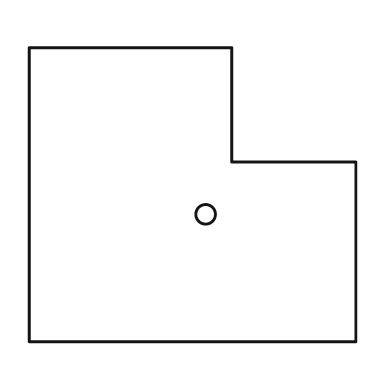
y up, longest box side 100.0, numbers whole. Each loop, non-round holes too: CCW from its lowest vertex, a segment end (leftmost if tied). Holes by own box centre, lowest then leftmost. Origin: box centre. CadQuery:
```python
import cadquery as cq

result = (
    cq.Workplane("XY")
    .moveTo(-50.0, -45.0)
    .lineTo(50.0, -45.0)
    .lineTo(50.0, 10.0)
    .lineTo(12.0, 10.0)
    .lineTo(12.0, 45.0)
    .lineTo(-50.0, 45.0)
    .close()
    .moveTo(4.0, -6.0)
    .circle(3.0)
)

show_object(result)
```